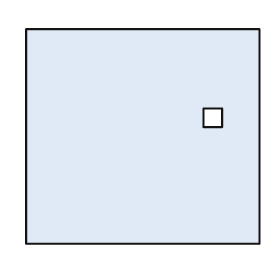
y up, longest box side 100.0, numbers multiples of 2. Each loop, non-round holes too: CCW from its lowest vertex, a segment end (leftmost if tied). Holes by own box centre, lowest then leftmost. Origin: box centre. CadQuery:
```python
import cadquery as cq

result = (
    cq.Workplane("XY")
    .moveTo(-50.0, -46.0)
    .lineTo(50.0, -46.0)
    .lineTo(50.0, 46.0)
    .lineTo(-50.0, 46.0)
    .close()
    .moveTo(26.0, 4.0)
    .lineTo(34.0, 4.0)
    .lineTo(34.0, 12.0)
    .lineTo(26.0, 12.0)
    .close()
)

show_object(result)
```